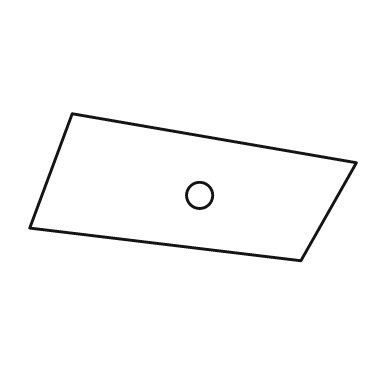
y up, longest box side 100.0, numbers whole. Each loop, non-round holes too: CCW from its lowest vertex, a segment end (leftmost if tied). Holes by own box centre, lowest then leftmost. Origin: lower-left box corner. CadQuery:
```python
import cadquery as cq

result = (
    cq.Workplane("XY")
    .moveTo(83.0, 0.0)
    .lineTo(100.0, 30.0)
    .lineTo(13.0, 45.0)
    .lineTo(0.0, 10.0)
    .close()
    .moveTo(52.0, 20.0)
    .circle(4.0)
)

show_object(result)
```